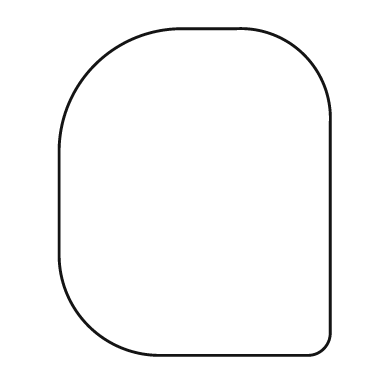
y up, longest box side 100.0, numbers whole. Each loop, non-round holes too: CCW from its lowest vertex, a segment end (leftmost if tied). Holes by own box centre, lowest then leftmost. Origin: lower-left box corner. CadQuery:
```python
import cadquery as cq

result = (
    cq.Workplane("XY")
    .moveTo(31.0, 0.0)
    .lineTo(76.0, 0.0)
    .threePointArc((81.0, 2.0), (83.0, 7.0))
    .lineTo(83.0, 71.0)
    .threePointArc((75.0, 92.0), (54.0, 100.0))
    .lineTo(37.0, 100.0)
    .threePointArc((11.0, 89.0), (0.0, 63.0))
    .lineTo(0.0, 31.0)
    .threePointArc((9.0, 9.0), (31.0, 0.0))
    .close()
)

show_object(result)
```